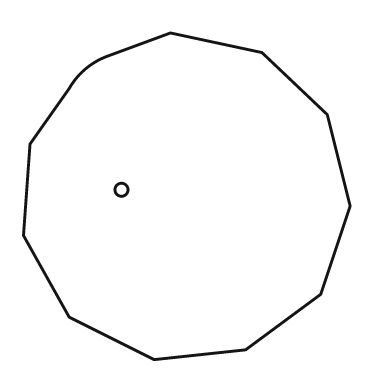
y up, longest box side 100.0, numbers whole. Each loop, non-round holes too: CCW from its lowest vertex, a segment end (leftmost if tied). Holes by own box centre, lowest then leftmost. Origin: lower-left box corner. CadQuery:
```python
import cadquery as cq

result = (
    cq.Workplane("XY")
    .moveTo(40.0, 0.0)
    .lineTo(68.0, 3.0)
    .lineTo(91.0, 20.0)
    .lineTo(100.0, 47.0)
    .lineTo(93.0, 75.0)
    .lineTo(73.0, 94.0)
    .lineTo(45.0, 100.0)
    .lineTo(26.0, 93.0)
    .threePointArc((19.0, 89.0), (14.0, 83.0))
    .lineTo(2.0, 66.0)
    .lineTo(0.0, 38.0)
    .lineTo(14.0, 13.0)
    .close()
    .moveTo(30.0, 52.0)
    .circle(2.0)
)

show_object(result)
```